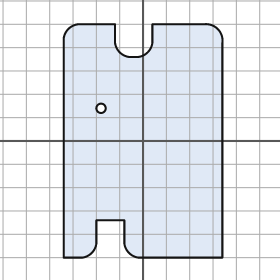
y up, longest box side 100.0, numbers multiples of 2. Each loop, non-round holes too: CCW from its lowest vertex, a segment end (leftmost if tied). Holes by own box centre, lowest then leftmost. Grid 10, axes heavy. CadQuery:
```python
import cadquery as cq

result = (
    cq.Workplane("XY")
    .moveTo(-34.0, -50.0)
    .lineTo(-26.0, -50.0)
    .threePointArc((-22.0, -48.0), (-20.0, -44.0))
    .lineTo(-20.0, -34.0)
    .lineTo(-8.0, -34.0)
    .lineTo(-8.0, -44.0)
    .threePointArc((-6.0, -48.0), (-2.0, -50.0))
    .lineTo(34.0, -50.0)
    .lineTo(34.0, 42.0)
    .threePointArc((32.0, 48.0), (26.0, 50.0))
    .lineTo(4.0, 50.0)
    .lineTo(4.0, 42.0)
    .threePointArc((2.0, 38.0), (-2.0, 36.0))
    .lineTo(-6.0, 36.0)
    .threePointArc((-10.0, 38.0), (-12.0, 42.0))
    .lineTo(-12.0, 50.0)
    .lineTo(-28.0, 50.0)
    .threePointArc((-32.0, 48.0), (-34.0, 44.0))
    .close()
    .moveTo(-18.0, 14.0)
    .circle(2.0)
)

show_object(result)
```